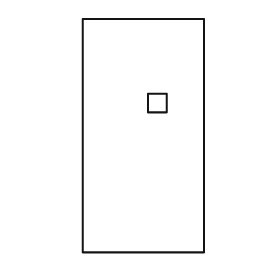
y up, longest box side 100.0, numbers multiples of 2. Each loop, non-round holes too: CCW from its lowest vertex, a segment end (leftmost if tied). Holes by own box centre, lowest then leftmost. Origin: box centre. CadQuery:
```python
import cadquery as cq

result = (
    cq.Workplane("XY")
    .moveTo(-26.0, -50.0)
    .lineTo(26.0, -50.0)
    .lineTo(26.0, 50.0)
    .lineTo(-26.0, 50.0)
    .close()
    .moveTo(2.0, 10.0)
    .lineTo(10.0, 10.0)
    .lineTo(10.0, 18.0)
    .lineTo(2.0, 18.0)
    .close()
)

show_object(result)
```